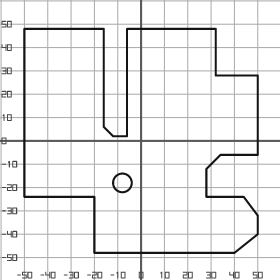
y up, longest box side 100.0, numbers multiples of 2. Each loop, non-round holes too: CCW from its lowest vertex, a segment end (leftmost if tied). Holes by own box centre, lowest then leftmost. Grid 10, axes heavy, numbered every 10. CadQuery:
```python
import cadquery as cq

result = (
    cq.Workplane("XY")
    .moveTo(-20.0, -48.0)
    .lineTo(40.0, -48.0)
    .lineTo(50.0, -40.0)
    .lineTo(50.0, -32.0)
    .lineTo(44.0, -24.0)
    .lineTo(28.0, -24.0)
    .lineTo(28.0, -12.0)
    .lineTo(34.0, -6.0)
    .lineTo(50.0, -6.0)
    .lineTo(50.0, 28.0)
    .lineTo(32.0, 28.0)
    .lineTo(32.0, 48.0)
    .lineTo(-6.0, 48.0)
    .lineTo(-6.0, 2.0)
    .lineTo(-12.0, 2.0)
    .lineTo(-16.0, 6.0)
    .lineTo(-16.0, 48.0)
    .lineTo(-50.0, 48.0)
    .lineTo(-50.0, -24.0)
    .lineTo(-20.0, -24.0)
    .close()
    .moveTo(-8.0, -18.0)
    .circle(4.0)
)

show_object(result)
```